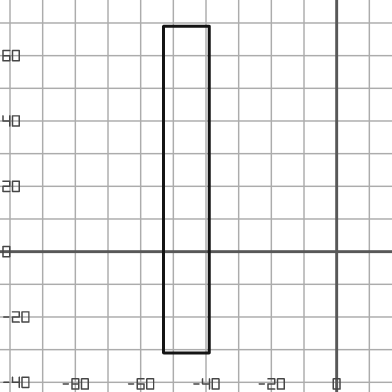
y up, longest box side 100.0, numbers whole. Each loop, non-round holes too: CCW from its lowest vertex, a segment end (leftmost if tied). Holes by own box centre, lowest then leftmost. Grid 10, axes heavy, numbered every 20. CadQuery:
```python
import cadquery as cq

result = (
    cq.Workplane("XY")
    .moveTo(-53.0, -31.0)
    .lineTo(-39.0, -31.0)
    .lineTo(-39.0, 69.0)
    .lineTo(-53.0, 69.0)
    .close()
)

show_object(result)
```